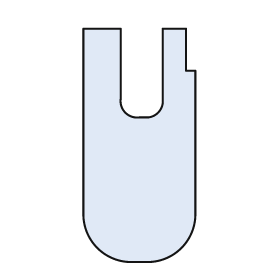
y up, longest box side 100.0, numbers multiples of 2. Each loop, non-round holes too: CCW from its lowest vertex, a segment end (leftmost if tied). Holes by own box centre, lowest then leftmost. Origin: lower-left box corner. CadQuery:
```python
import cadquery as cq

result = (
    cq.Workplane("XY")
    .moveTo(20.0, 0.0)
    .lineTo(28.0, 0.0)
    .threePointArc((42.0, 6.0), (48.0, 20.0))
    .lineTo(48.0, 82.0)
    .lineTo(44.0, 82.0)
    .lineTo(44.0, 100.0)
    .lineTo(34.0, 100.0)
    .lineTo(34.0, 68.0)
    .threePointArc((32.0, 64.0), (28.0, 62.0))
    .lineTo(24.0, 62.0)
    .threePointArc((18.0, 64.0), (16.0, 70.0))
    .lineTo(16.0, 100.0)
    .lineTo(0.0, 100.0)
    .lineTo(0.0, 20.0)
    .threePointArc((6.0, 6.0), (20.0, 0.0))
    .close()
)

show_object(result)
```